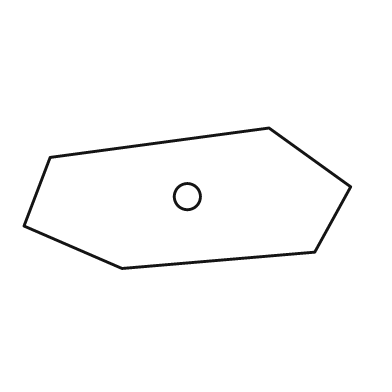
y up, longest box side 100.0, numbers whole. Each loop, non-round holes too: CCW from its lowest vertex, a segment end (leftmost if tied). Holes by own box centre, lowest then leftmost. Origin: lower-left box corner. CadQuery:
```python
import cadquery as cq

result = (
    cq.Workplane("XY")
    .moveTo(30.0, 0.0)
    .lineTo(89.0, 5.0)
    .lineTo(100.0, 25.0)
    .lineTo(75.0, 43.0)
    .lineTo(8.0, 34.0)
    .lineTo(0.0, 13.0)
    .close()
    .moveTo(50.0, 22.0)
    .circle(4.0)
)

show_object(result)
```